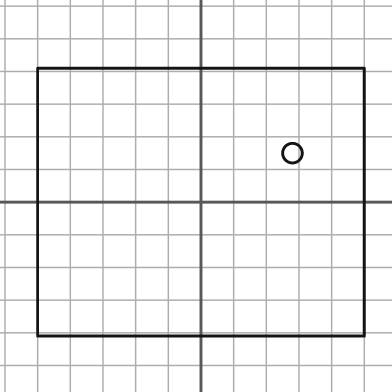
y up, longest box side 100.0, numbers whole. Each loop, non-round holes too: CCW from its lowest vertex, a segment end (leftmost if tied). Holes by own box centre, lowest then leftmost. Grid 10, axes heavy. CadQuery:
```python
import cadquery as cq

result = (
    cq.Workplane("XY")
    .moveTo(-50.0, -41.0)
    .lineTo(50.0, -41.0)
    .lineTo(50.0, 41.0)
    .lineTo(-50.0, 41.0)
    .close()
    .moveTo(28.0, 15.0)
    .circle(3.0)
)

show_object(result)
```